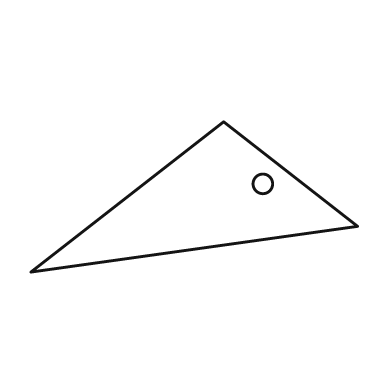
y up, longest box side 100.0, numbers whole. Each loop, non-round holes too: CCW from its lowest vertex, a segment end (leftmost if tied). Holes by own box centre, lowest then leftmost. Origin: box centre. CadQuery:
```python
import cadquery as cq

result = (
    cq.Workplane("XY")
    .moveTo(-50.0, -23.0)
    .lineTo(50.0, -9.0)
    .lineTo(9.0, 23.0)
    .close()
    .moveTo(21.0, 4.0)
    .circle(3.0)
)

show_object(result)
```